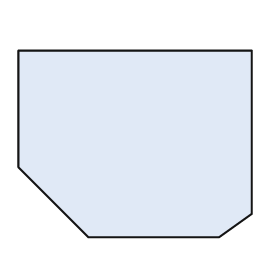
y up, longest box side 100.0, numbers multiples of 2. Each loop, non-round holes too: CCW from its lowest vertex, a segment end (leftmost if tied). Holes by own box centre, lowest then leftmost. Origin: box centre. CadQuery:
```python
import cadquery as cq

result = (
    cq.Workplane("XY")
    .moveTo(-20.0, -40.0)
    .lineTo(36.0, -40.0)
    .lineTo(50.0, -30.0)
    .lineTo(50.0, 40.0)
    .lineTo(-50.0, 40.0)
    .lineTo(-50.0, -10.0)
    .close()
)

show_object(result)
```